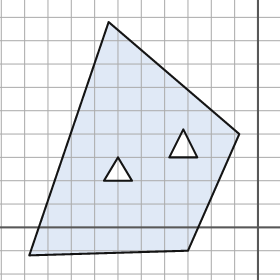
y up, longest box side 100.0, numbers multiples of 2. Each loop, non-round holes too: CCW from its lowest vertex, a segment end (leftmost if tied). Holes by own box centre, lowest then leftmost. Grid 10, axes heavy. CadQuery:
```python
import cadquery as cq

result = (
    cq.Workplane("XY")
    .moveTo(-98.0, -12.0)
    .lineTo(-30.0, -10.0)
    .lineTo(-8.0, 40.0)
    .lineTo(-64.0, 88.0)
    .close()
    .moveTo(-66.0, 20.0)
    .lineTo(-54.0, 20.0)
    .lineTo(-60.0, 30.0)
    .close()
    .moveTo(-38.0, 30.0)
    .lineTo(-26.0, 30.0)
    .lineTo(-32.0, 42.0)
    .close()
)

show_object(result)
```